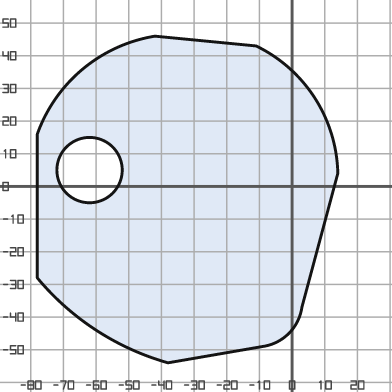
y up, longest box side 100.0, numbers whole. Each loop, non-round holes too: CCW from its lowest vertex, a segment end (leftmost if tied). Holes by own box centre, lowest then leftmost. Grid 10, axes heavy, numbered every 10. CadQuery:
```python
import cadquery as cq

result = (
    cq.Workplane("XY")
    .moveTo(-38.0, -54.0)
    .lineTo(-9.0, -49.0)
    .threePointArc((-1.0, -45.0), (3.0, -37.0))
    .lineTo(14.0, 4.0)
    .threePointArc((7.0, 27.0), (-11.0, 43.0))
    .lineTo(-42.0, 46.0)
    .threePointArc((-64.0, 36.0), (-78.0, 16.0))
    .lineTo(-78.0, -28.0)
    .threePointArc((-60.0, -44.0), (-38.0, -54.0))
    .close()
    .moveTo(-62.0, 5.0)
    .circle(10.0)
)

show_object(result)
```